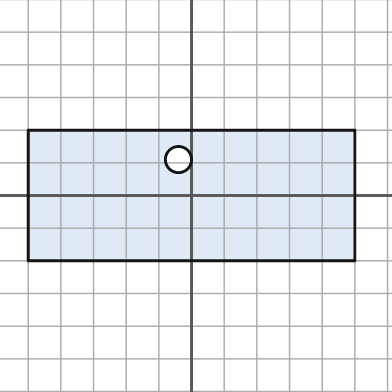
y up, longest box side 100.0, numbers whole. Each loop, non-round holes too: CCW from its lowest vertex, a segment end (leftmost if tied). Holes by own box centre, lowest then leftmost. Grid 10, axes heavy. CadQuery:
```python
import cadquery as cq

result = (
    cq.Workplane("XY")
    .moveTo(-50.0, -20.0)
    .lineTo(50.0, -20.0)
    .lineTo(50.0, 20.0)
    .lineTo(-50.0, 20.0)
    .close()
    .moveTo(-4.0, 11.0)
    .circle(4.0)
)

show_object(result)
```